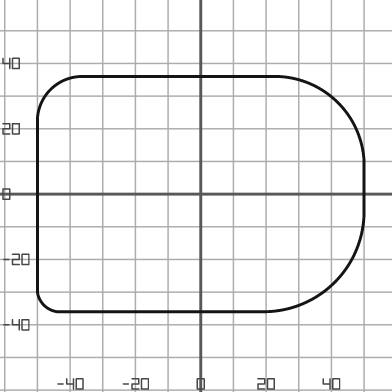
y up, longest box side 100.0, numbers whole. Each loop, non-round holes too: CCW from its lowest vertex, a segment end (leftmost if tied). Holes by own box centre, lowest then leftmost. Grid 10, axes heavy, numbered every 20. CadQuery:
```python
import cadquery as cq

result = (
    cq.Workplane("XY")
    .moveTo(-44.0, -36.0)
    .lineTo(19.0, -36.0)
    .threePointArc((41.0, -27.0), (50.0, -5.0))
    .lineTo(50.0, 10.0)
    .threePointArc((42.0, 28.0), (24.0, 36.0))
    .lineTo(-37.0, 36.0)
    .threePointArc((-46.0, 32.0), (-50.0, 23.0))
    .lineTo(-50.0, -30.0)
    .threePointArc((-48.0, -34.0), (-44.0, -36.0))
    .close()
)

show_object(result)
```